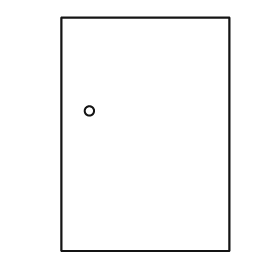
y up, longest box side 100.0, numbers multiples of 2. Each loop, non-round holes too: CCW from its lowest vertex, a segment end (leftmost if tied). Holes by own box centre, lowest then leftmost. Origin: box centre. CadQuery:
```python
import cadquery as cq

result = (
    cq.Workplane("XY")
    .moveTo(-36.0, -50.0)
    .lineTo(36.0, -50.0)
    .lineTo(36.0, 50.0)
    .lineTo(-36.0, 50.0)
    .close()
    .moveTo(-24.0, 10.0)
    .circle(2.0)
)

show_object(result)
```